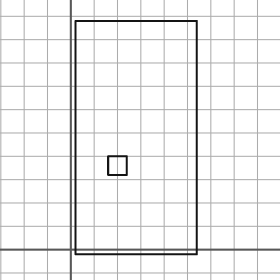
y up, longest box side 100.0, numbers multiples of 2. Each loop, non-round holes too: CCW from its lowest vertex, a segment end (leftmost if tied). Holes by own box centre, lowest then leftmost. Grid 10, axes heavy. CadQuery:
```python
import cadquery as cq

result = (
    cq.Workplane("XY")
    .moveTo(2.0, -2.0)
    .lineTo(54.0, -2.0)
    .lineTo(54.0, 98.0)
    .lineTo(2.0, 98.0)
    .close()
    .moveTo(16.0, 32.0)
    .lineTo(24.0, 32.0)
    .lineTo(24.0, 40.0)
    .lineTo(16.0, 40.0)
    .close()
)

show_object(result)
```